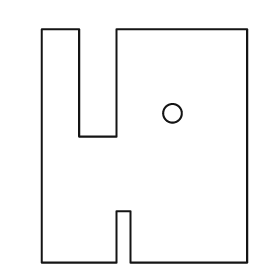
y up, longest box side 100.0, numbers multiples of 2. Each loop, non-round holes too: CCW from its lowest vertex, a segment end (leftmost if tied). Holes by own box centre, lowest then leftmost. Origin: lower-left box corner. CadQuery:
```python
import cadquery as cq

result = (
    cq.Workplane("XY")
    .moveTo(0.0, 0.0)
    .lineTo(32.0, 0.0)
    .lineTo(32.0, 22.0)
    .lineTo(38.0, 22.0)
    .lineTo(38.0, 0.0)
    .lineTo(88.0, 0.0)
    .lineTo(88.0, 100.0)
    .lineTo(32.0, 100.0)
    .lineTo(32.0, 54.0)
    .lineTo(16.0, 54.0)
    .lineTo(16.0, 100.0)
    .lineTo(0.0, 100.0)
    .close()
    .moveTo(56.0, 64.0)
    .circle(4.0)
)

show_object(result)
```